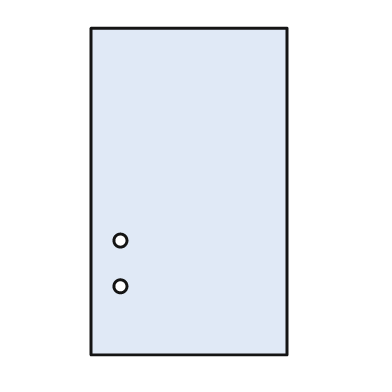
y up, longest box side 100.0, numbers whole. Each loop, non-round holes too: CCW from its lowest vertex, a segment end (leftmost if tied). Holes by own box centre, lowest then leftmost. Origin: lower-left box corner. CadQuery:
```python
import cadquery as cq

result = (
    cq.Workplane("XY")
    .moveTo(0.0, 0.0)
    .lineTo(60.0, 0.0)
    .lineTo(60.0, 100.0)
    .lineTo(0.0, 100.0)
    .close()
    .moveTo(9.0, 21.0)
    .circle(2.0)
    .moveTo(9.0, 35.0)
    .circle(2.0)
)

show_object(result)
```